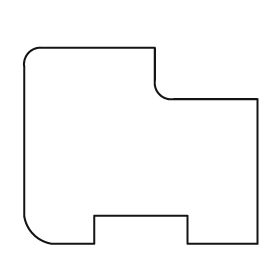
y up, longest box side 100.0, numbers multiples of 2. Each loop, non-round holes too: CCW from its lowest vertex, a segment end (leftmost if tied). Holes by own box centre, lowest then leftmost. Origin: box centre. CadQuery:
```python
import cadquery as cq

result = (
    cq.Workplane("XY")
    .moveTo(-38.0, -42.0)
    .lineTo(-20.0, -42.0)
    .lineTo(-20.0, -30.0)
    .lineTo(20.0, -30.0)
    .lineTo(20.0, -42.0)
    .lineTo(50.0, -42.0)
    .lineTo(50.0, 20.0)
    .lineTo(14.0, 20.0)
    .threePointArc((8.0, 22.0), (6.0, 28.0))
    .lineTo(6.0, 42.0)
    .lineTo(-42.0, 42.0)
    .threePointArc((-48.0, 40.0), (-50.0, 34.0))
    .lineTo(-50.0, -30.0)
    .threePointArc((-46.0, -38.0), (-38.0, -42.0))
    .close()
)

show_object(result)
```